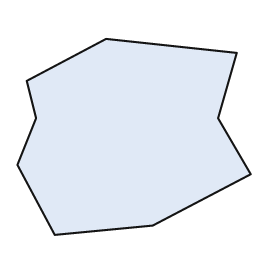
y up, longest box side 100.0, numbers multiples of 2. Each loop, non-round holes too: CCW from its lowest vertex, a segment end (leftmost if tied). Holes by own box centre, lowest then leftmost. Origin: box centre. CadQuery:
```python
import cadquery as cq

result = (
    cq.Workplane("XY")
    .moveTo(-34.0, -42.0)
    .lineTo(8.0, -38.0)
    .lineTo(50.0, -16.0)
    .lineTo(36.0, 8.0)
    .lineTo(44.0, 36.0)
    .lineTo(-12.0, 42.0)
    .lineTo(-46.0, 24.0)
    .lineTo(-42.0, 8.0)
    .lineTo(-50.0, -12.0)
    .close()
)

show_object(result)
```